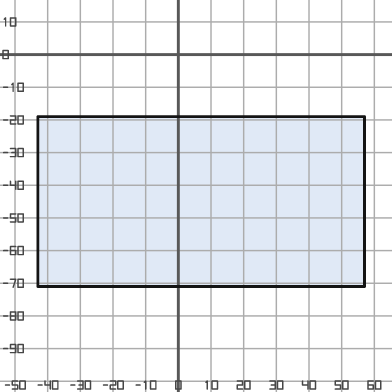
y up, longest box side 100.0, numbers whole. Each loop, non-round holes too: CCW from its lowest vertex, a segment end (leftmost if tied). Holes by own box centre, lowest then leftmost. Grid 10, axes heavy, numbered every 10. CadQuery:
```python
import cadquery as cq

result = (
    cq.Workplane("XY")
    .moveTo(-43.0, -71.0)
    .lineTo(57.0, -71.0)
    .lineTo(57.0, -19.0)
    .lineTo(-43.0, -19.0)
    .close()
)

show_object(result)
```